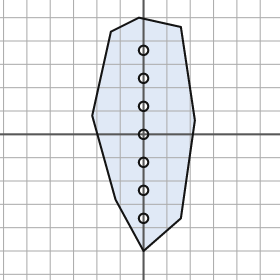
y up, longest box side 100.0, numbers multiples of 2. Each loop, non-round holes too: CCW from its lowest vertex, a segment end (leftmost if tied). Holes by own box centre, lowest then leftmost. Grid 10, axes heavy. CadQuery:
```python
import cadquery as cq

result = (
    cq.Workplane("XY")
    .moveTo(0.0, -50.0)
    .lineTo(16.0, -36.0)
    .lineTo(22.0, 6.0)
    .lineTo(16.0, 46.0)
    .lineTo(-2.0, 50.0)
    .lineTo(-14.0, 44.0)
    .lineTo(-22.0, 8.0)
    .lineTo(-12.0, -28.0)
    .close()
    .moveTo(0.0, -36.0)
    .circle(2.0)
    .moveTo(0.0, -24.0)
    .circle(2.0)
    .moveTo(0.0, -12.0)
    .circle(2.0)
    .moveTo(0.0, 0.0)
    .circle(2.0)
    .moveTo(0.0, 12.0)
    .circle(2.0)
    .moveTo(0.0, 24.0)
    .circle(2.0)
    .moveTo(0.0, 36.0)
    .circle(2.0)
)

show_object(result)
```